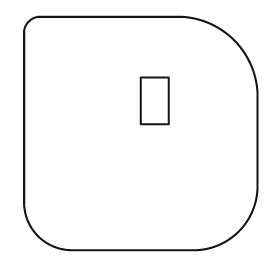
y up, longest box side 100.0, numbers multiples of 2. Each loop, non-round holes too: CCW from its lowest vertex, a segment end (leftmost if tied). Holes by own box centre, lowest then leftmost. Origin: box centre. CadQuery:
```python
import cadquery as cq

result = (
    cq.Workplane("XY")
    .moveTo(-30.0, -50.0)
    .lineTo(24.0, -50.0)
    .threePointArc((42.0, -42.0), (50.0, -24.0))
    .lineTo(50.0, 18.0)
    .threePointArc((40.0, 40.0), (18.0, 50.0))
    .lineTo(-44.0, 50.0)
    .threePointArc((-48.0, 48.0), (-50.0, 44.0))
    .lineTo(-50.0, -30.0)
    .threePointArc((-44.0, -44.0), (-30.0, -50.0))
    .close()
    .moveTo(0.0, 4.0)
    .lineTo(12.0, 4.0)
    .lineTo(12.0, 24.0)
    .lineTo(0.0, 24.0)
    .close()
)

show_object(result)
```